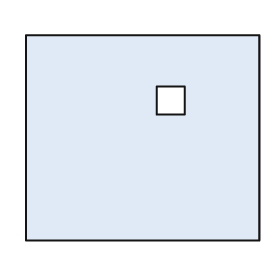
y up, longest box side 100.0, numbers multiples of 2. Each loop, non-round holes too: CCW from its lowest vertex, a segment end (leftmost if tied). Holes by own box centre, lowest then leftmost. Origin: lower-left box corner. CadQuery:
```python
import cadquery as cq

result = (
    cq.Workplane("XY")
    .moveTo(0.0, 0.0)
    .lineTo(100.0, 0.0)
    .lineTo(100.0, 88.0)
    .lineTo(0.0, 88.0)
    .close()
    .moveTo(56.0, 54.0)
    .lineTo(68.0, 54.0)
    .lineTo(68.0, 66.0)
    .lineTo(56.0, 66.0)
    .close()
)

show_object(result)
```